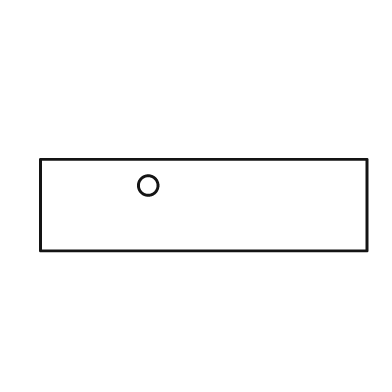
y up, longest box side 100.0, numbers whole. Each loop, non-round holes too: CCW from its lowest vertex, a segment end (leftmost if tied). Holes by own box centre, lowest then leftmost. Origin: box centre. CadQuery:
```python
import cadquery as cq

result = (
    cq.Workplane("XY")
    .moveTo(-50.0, -14.0)
    .lineTo(50.0, -14.0)
    .lineTo(50.0, 14.0)
    .lineTo(-50.0, 14.0)
    .close()
    .moveTo(-17.0, 6.0)
    .circle(3.0)
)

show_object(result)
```